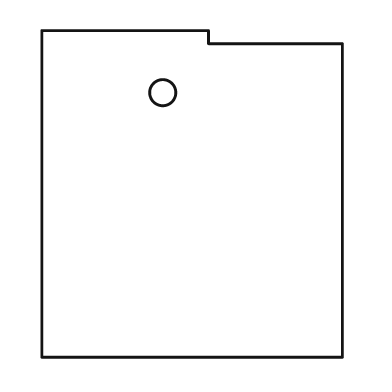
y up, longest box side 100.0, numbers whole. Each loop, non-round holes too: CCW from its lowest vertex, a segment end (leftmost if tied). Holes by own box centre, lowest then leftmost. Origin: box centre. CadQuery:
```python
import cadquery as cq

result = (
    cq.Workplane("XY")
    .moveTo(-46.0, -50.0)
    .lineTo(46.0, -50.0)
    .lineTo(46.0, 46.0)
    .lineTo(5.0, 46.0)
    .lineTo(5.0, 50.0)
    .lineTo(-46.0, 50.0)
    .close()
    .moveTo(-9.0, 31.0)
    .circle(4.0)
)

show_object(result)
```